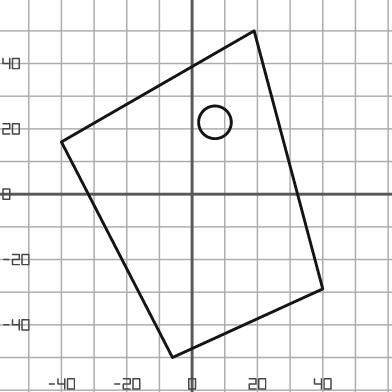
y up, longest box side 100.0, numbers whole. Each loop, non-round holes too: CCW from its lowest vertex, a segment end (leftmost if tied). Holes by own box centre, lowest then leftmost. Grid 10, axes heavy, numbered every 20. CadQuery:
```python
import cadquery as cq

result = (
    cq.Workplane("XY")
    .moveTo(-6.0, -50.0)
    .lineTo(40.0, -29.0)
    .lineTo(19.0, 50.0)
    .lineTo(-40.0, 16.0)
    .close()
    .moveTo(7.0, 22.0)
    .circle(5.0)
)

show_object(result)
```